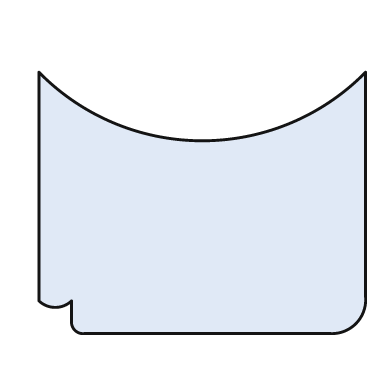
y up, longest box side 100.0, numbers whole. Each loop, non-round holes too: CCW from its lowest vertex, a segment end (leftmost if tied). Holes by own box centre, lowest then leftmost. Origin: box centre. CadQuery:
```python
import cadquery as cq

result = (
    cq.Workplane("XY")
    .moveTo(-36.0, -40.0)
    .lineTo(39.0, -40.0)
    .threePointArc((47.0, -37.0), (50.0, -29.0))
    .lineTo(50.0, 40.0)
    .threePointArc((0.0, 19.0), (-50.0, 40.0))
    .lineTo(-50.0, -30.0)
    .threePointArc((-45.0, -32.0), (-40.0, -30.0))
    .lineTo(-40.0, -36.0)
    .threePointArc((-39.0, -39.0), (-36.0, -40.0))
    .close()
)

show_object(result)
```